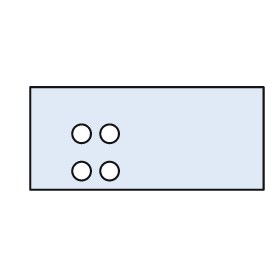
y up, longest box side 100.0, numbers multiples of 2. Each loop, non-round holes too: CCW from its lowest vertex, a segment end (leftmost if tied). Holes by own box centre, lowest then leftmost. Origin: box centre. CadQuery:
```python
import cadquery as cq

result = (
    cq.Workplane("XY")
    .moveTo(-50.0, -22.0)
    .lineTo(50.0, -22.0)
    .lineTo(50.0, 22.0)
    .lineTo(-50.0, 22.0)
    .close()
    .moveTo(-28.0, -14.0)
    .circle(4.0)
    .moveTo(-16.0, -14.0)
    .circle(4.0)
    .moveTo(-28.0, 2.0)
    .circle(4.0)
    .moveTo(-16.0, 2.0)
    .circle(4.0)
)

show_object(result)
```